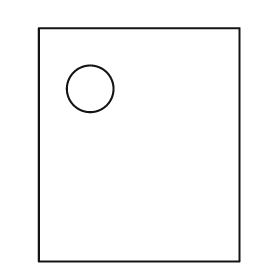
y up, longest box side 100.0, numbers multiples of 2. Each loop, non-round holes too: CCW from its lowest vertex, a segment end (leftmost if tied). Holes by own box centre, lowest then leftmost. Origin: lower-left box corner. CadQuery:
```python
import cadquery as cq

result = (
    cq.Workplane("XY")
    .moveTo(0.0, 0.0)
    .lineTo(86.0, 0.0)
    .lineTo(86.0, 100.0)
    .lineTo(0.0, 100.0)
    .close()
    .moveTo(22.0, 74.0)
    .circle(10.0)
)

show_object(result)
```